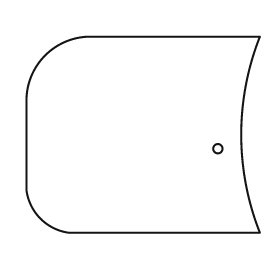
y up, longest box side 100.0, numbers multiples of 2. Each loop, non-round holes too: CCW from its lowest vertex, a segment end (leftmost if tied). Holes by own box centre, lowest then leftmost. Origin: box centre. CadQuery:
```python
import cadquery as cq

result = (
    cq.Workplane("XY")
    .moveTo(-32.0, -42.0)
    .lineTo(50.0, -42.0)
    .threePointArc((42.0, 0.0), (50.0, 42.0))
    .lineTo(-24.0, 42.0)
    .threePointArc((-42.0, 34.0), (-50.0, 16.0))
    .lineTo(-50.0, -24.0)
    .threePointArc((-44.0, -36.0), (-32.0, -42.0))
    .close()
    .moveTo(32.0, -6.0)
    .circle(2.0)
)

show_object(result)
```